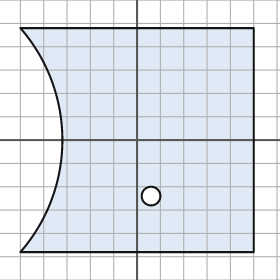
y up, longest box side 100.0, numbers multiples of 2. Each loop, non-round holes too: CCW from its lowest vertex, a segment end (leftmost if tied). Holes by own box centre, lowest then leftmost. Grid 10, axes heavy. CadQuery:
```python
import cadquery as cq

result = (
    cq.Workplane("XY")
    .moveTo(-50.0, -48.0)
    .lineTo(50.0, -48.0)
    .lineTo(50.0, 48.0)
    .lineTo(-50.0, 48.0)
    .threePointArc((-32.0, 0.0), (-50.0, -48.0))
    .close()
    .moveTo(6.0, -24.0)
    .circle(4.0)
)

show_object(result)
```